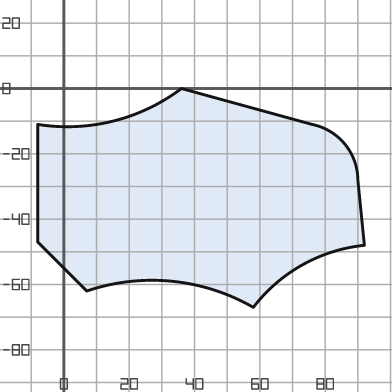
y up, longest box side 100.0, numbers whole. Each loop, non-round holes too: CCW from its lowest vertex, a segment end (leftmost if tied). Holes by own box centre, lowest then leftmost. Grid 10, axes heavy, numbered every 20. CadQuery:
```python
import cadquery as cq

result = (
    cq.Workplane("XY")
    .moveTo(58.0, -67.0)
    .threePointArc((73.0, -54.0), (92.0, -48.0))
    .lineTo(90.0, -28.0)
    .threePointArc((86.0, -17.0), (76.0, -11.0))
    .lineTo(36.0, 0.0)
    .threePointArc((15.0, -10.0), (-8.0, -11.0))
    .lineTo(-8.0, -47.0)
    .lineTo(7.0, -62.0)
    .threePointArc((33.0, -59.0), (58.0, -67.0))
    .close()
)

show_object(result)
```